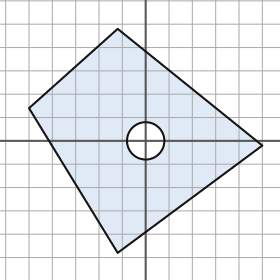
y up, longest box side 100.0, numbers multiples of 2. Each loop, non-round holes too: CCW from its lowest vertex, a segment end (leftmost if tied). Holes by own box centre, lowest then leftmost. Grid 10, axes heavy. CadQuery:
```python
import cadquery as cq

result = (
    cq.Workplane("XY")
    .moveTo(-12.0, -48.0)
    .lineTo(50.0, -2.0)
    .lineTo(-12.0, 48.0)
    .lineTo(-50.0, 14.0)
    .close()
    .moveTo(0.0, 0.0)
    .circle(8.0)
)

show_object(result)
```